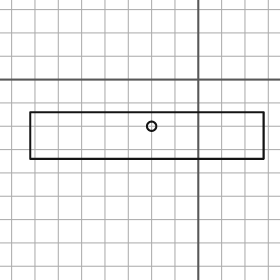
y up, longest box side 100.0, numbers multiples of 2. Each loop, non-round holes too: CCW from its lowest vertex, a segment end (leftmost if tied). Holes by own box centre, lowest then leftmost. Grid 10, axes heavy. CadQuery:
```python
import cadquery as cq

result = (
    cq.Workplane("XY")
    .moveTo(-72.0, -34.0)
    .lineTo(28.0, -34.0)
    .lineTo(28.0, -14.0)
    .lineTo(-72.0, -14.0)
    .close()
    .moveTo(-20.0, -20.0)
    .circle(2.0)
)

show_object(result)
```